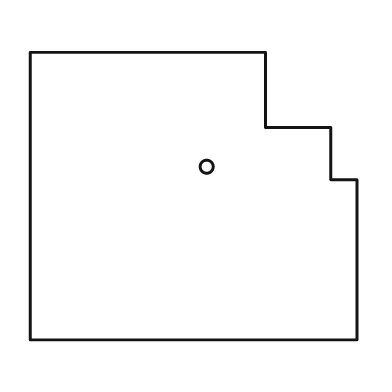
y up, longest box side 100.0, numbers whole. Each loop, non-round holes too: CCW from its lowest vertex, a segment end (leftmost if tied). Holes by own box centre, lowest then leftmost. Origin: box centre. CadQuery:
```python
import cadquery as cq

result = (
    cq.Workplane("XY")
    .moveTo(-50.0, -44.0)
    .lineTo(50.0, -44.0)
    .lineTo(50.0, 5.0)
    .lineTo(42.0, 5.0)
    .lineTo(42.0, 21.0)
    .lineTo(22.0, 21.0)
    .lineTo(22.0, 44.0)
    .lineTo(-50.0, 44.0)
    .close()
    .moveTo(4.0, 9.0)
    .circle(2.0)
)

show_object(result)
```